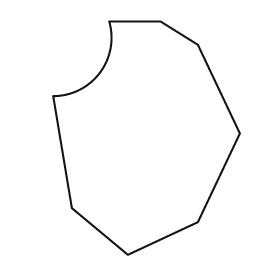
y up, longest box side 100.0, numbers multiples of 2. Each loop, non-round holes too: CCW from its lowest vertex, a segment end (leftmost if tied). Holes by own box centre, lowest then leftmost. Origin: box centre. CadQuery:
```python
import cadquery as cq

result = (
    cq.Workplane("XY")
    .moveTo(-8.0, -50.0)
    .lineTo(22.0, -36.0)
    .lineTo(40.0, 2.0)
    .lineTo(22.0, 40.0)
    .lineTo(6.0, 50.0)
    .lineTo(-16.0, 50.0)
    .threePointArc((-20.0, 28.0), (-40.0, 18.0))
    .lineTo(-32.0, -30.0)
    .close()
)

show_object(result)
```